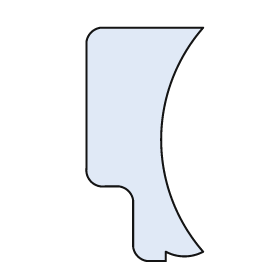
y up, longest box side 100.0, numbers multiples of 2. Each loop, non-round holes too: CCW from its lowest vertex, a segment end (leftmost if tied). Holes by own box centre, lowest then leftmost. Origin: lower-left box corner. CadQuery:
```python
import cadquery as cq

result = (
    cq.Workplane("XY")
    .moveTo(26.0, 0.0)
    .lineTo(34.0, 0.0)
    .lineTo(34.0, 4.0)
    .threePointArc((42.0, 2.0), (50.0, 4.0))
    .threePointArc((32.0, 52.0), (50.0, 100.0))
    .lineTo(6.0, 100.0)
    .threePointArc((2.0, 98.0), (0.0, 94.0))
    .lineTo(0.0, 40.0)
    .threePointArc((2.0, 34.0), (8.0, 32.0))
    .lineTo(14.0, 32.0)
    .threePointArc((18.0, 30.0), (20.0, 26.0))
    .lineTo(20.0, 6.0)
    .threePointArc((22.0, 2.0), (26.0, 0.0))
    .close()
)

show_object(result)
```